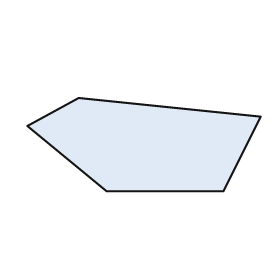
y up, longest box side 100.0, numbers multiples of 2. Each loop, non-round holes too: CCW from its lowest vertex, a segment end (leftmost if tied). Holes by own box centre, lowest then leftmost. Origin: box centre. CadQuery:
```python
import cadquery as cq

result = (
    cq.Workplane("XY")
    .moveTo(-16.0, -20.0)
    .lineTo(34.0, -20.0)
    .lineTo(50.0, 12.0)
    .lineTo(-28.0, 20.0)
    .lineTo(-50.0, 8.0)
    .close()
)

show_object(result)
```